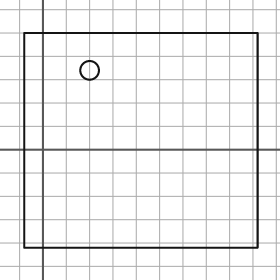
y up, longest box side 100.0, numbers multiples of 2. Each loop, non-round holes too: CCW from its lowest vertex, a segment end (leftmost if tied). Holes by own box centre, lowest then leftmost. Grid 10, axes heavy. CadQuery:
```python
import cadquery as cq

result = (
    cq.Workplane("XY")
    .moveTo(-8.0, -42.0)
    .lineTo(92.0, -42.0)
    .lineTo(92.0, 50.0)
    .lineTo(-8.0, 50.0)
    .close()
    .moveTo(20.0, 34.0)
    .circle(4.0)
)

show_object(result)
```